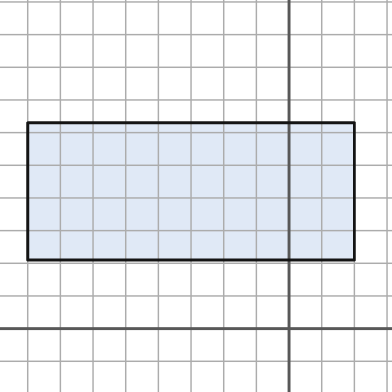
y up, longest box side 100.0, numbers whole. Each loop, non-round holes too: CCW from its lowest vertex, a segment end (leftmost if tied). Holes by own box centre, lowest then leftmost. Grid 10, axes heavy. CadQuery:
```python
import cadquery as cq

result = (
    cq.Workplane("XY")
    .moveTo(-80.0, 21.0)
    .lineTo(20.0, 21.0)
    .lineTo(20.0, 63.0)
    .lineTo(-80.0, 63.0)
    .close()
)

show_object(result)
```